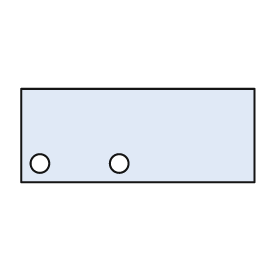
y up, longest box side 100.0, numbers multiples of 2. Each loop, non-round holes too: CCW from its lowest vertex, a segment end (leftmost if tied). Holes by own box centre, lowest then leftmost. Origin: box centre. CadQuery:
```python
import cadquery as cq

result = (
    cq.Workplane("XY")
    .moveTo(-50.0, -20.0)
    .lineTo(50.0, -20.0)
    .lineTo(50.0, 20.0)
    .lineTo(-50.0, 20.0)
    .close()
    .moveTo(-42.0, -12.0)
    .circle(4.0)
    .moveTo(-8.0, -12.0)
    .circle(4.0)
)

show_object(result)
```